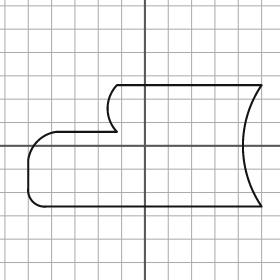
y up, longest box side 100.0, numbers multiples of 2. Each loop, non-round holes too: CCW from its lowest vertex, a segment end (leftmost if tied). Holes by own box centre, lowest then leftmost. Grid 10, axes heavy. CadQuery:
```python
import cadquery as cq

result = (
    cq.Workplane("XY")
    .moveTo(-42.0, -26.0)
    .lineTo(50.0, -26.0)
    .threePointArc((42.0, 0.0), (50.0, 26.0))
    .lineTo(-12.0, 26.0)
    .threePointArc((-16.0, 16.0), (-12.0, 6.0))
    .lineTo(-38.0, 6.0)
    .threePointArc((-46.0, 2.0), (-50.0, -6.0))
    .lineTo(-50.0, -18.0)
    .threePointArc((-48.0, -24.0), (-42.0, -26.0))
    .close()
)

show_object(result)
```